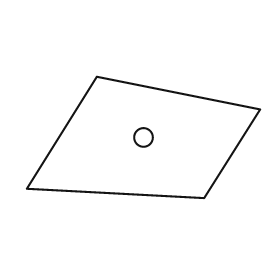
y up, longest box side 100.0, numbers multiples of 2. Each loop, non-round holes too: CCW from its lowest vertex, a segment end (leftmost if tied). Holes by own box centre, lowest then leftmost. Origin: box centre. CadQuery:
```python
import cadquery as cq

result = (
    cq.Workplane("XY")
    .moveTo(26.0, -26.0)
    .lineTo(50.0, 12.0)
    .lineTo(-20.0, 26.0)
    .lineTo(-50.0, -22.0)
    .close()
    .moveTo(0.0, 0.0)
    .circle(4.0)
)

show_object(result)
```